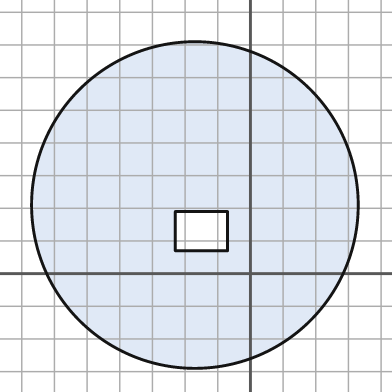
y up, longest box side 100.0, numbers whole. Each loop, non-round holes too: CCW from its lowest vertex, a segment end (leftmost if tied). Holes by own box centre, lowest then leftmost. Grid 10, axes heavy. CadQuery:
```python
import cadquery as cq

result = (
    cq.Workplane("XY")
    .moveTo(-17.0, 21.0)
    .circle(50.0)
    .moveTo(-23.0, 7.0)
    .lineTo(-7.0, 7.0)
    .lineTo(-7.0, 19.0)
    .lineTo(-23.0, 19.0)
    .close()
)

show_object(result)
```